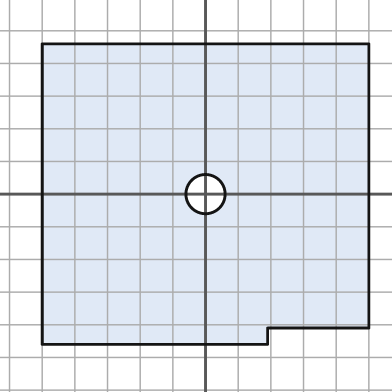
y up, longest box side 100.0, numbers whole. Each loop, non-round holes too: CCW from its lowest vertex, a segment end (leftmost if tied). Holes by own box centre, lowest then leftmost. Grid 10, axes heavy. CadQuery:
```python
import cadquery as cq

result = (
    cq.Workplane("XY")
    .moveTo(-50.0, -46.0)
    .lineTo(19.0, -46.0)
    .lineTo(19.0, -41.0)
    .lineTo(50.0, -41.0)
    .lineTo(50.0, 46.0)
    .lineTo(-50.0, 46.0)
    .close()
    .moveTo(0.0, 0.0)
    .circle(6.0)
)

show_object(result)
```